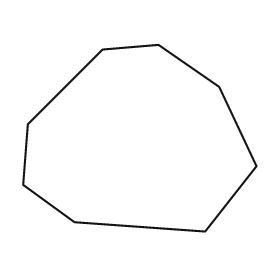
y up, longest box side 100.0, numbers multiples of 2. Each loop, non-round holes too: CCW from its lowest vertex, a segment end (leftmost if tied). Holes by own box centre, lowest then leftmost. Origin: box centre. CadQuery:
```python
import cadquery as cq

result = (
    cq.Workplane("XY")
    .moveTo(28.0, -40.0)
    .lineTo(50.0, -12.0)
    .lineTo(34.0, 22.0)
    .lineTo(8.0, 40.0)
    .lineTo(-16.0, 38.0)
    .lineTo(-48.0, 6.0)
    .lineTo(-50.0, -20.0)
    .lineTo(-28.0, -36.0)
    .close()
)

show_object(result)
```